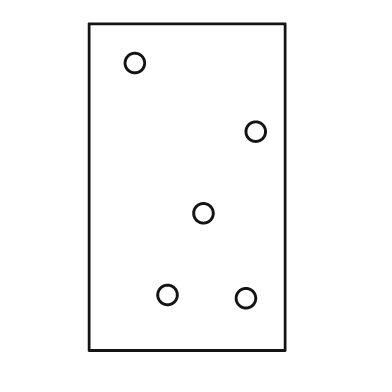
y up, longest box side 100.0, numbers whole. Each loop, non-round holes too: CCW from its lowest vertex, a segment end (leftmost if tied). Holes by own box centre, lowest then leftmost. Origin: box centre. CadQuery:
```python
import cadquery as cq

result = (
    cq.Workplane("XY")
    .moveTo(-30.0, -50.0)
    .lineTo(30.0, -50.0)
    .lineTo(30.0, 50.0)
    .lineTo(-30.0, 50.0)
    .close()
    .moveTo(18.0, -34.0)
    .circle(3.0)
    .moveTo(-6.0, -33.0)
    .circle(3.0)
    .moveTo(5.0, -8.0)
    .circle(3.0)
    .moveTo(21.0, 17.0)
    .circle(3.0)
    .moveTo(-16.0, 38.0)
    .circle(3.0)
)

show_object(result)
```